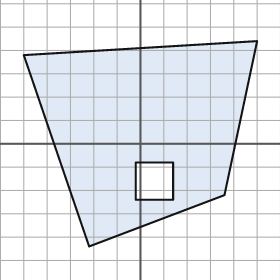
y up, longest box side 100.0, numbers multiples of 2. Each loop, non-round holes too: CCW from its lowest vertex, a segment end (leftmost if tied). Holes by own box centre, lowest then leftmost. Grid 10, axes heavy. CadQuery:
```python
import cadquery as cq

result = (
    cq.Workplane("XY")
    .moveTo(-22.0, -44.0)
    .lineTo(36.0, -22.0)
    .lineTo(50.0, 44.0)
    .lineTo(-50.0, 38.0)
    .close()
    .moveTo(-2.0, -24.0)
    .lineTo(14.0, -24.0)
    .lineTo(14.0, -8.0)
    .lineTo(-2.0, -8.0)
    .close()
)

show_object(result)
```